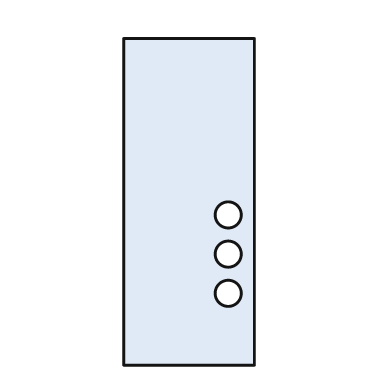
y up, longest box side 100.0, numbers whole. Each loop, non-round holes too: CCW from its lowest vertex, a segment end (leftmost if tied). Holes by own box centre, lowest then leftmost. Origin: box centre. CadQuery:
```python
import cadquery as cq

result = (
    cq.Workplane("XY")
    .moveTo(-20.0, -50.0)
    .lineTo(20.0, -50.0)
    .lineTo(20.0, 50.0)
    .lineTo(-20.0, 50.0)
    .close()
    .moveTo(12.0, -28.0)
    .circle(4.0)
    .moveTo(12.0, -16.0)
    .circle(4.0)
    .moveTo(12.0, -4.0)
    .circle(4.0)
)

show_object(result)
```